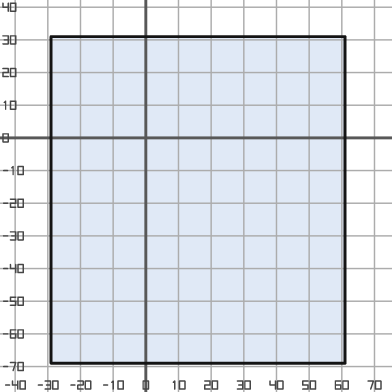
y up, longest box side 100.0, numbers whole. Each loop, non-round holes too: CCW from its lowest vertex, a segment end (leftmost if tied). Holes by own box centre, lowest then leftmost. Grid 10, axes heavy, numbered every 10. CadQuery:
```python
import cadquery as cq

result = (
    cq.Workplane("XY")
    .moveTo(-29.0, -69.0)
    .lineTo(61.0, -69.0)
    .lineTo(61.0, 31.0)
    .lineTo(-29.0, 31.0)
    .close()
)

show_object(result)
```